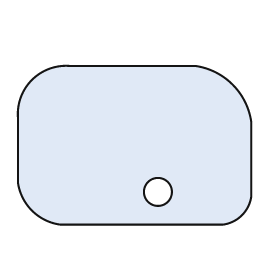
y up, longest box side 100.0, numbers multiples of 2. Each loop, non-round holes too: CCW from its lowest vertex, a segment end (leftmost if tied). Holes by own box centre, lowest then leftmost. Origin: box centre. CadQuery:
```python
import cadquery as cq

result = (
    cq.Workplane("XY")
    .moveTo(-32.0, -34.0)
    .lineTo(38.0, -34.0)
    .threePointArc((46.0, -30.0), (50.0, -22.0))
    .lineTo(50.0, 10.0)
    .threePointArc((42.0, 26.0), (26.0, 34.0))
    .lineTo(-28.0, 34.0)
    .threePointArc((-44.0, 28.0), (-50.0, 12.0))
    .lineTo(-50.0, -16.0)
    .threePointArc((-44.0, -28.0), (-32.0, -34.0))
    .close()
    .moveTo(10.0, -20.0)
    .circle(6.0)
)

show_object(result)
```